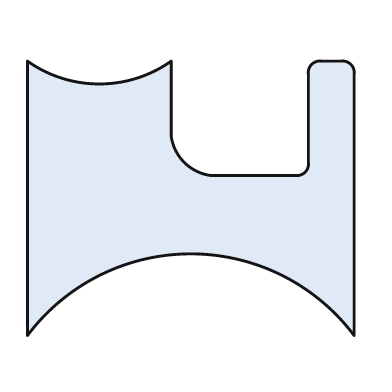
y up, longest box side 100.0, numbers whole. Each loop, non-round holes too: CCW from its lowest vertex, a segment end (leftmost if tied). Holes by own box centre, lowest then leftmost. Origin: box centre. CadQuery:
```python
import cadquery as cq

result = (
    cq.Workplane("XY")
    .moveTo(-50.0, -42.0)
    .threePointArc((0.0, -17.0), (50.0, -42.0))
    .lineTo(50.0, 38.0)
    .threePointArc((49.0, 41.0), (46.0, 42.0))
    .lineTo(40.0, 42.0)
    .threePointArc((37.0, 41.0), (36.0, 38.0))
    .lineTo(36.0, 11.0)
    .threePointArc((35.0, 8.0), (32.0, 7.0))
    .lineTo(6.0, 7.0)
    .threePointArc((-2.0, 11.0), (-6.0, 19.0))
    .lineTo(-6.0, 42.0)
    .threePointArc((-28.0, 35.0), (-50.0, 42.0))
    .close()
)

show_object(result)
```